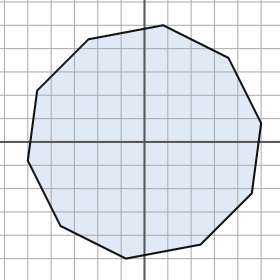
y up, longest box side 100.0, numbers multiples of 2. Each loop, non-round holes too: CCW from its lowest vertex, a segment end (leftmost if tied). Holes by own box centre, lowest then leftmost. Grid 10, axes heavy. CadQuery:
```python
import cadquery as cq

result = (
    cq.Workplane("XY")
    .moveTo(-8.0, -50.0)
    .lineTo(24.0, -44.0)
    .lineTo(46.0, -22.0)
    .lineTo(50.0, 8.0)
    .lineTo(36.0, 36.0)
    .lineTo(8.0, 50.0)
    .lineTo(-24.0, 44.0)
    .lineTo(-46.0, 22.0)
    .lineTo(-50.0, -8.0)
    .lineTo(-36.0, -36.0)
    .close()
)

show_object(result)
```